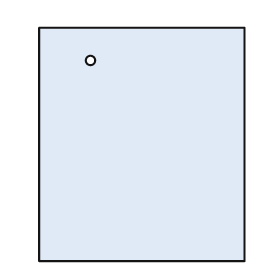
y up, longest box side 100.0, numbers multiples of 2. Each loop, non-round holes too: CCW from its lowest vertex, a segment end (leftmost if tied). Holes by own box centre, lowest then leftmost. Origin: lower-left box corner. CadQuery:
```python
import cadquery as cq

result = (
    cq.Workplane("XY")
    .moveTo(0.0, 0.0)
    .lineTo(88.0, 0.0)
    .lineTo(88.0, 100.0)
    .lineTo(0.0, 100.0)
    .close()
    .moveTo(22.0, 86.0)
    .circle(2.0)
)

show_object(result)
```